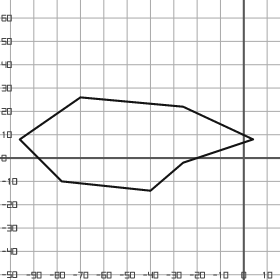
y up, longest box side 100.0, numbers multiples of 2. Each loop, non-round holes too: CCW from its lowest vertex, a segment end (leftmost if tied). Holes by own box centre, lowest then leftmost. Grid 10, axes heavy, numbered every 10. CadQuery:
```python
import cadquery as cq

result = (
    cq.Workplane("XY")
    .moveTo(-40.0, -14.0)
    .lineTo(-26.0, -2.0)
    .lineTo(4.0, 8.0)
    .lineTo(-26.0, 22.0)
    .lineTo(-70.0, 26.0)
    .lineTo(-96.0, 8.0)
    .lineTo(-78.0, -10.0)
    .close()
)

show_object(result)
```